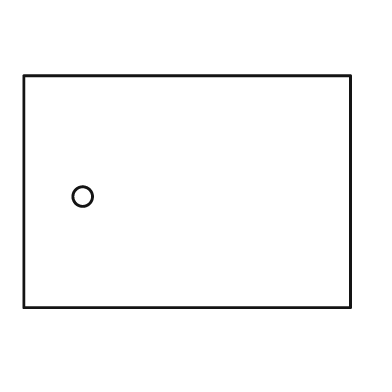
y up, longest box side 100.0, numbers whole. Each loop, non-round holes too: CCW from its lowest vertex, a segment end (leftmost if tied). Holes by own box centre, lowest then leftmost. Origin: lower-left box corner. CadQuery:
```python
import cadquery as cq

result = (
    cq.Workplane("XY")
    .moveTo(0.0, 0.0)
    .lineTo(100.0, 0.0)
    .lineTo(100.0, 71.0)
    .lineTo(0.0, 71.0)
    .close()
    .moveTo(18.0, 34.0)
    .circle(3.0)
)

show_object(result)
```